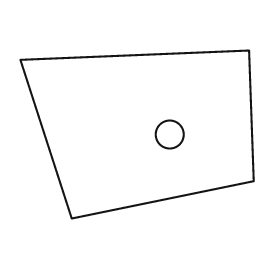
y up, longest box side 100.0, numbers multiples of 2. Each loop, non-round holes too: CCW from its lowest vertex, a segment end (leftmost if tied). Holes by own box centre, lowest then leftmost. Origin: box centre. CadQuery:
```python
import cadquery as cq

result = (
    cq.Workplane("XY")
    .moveTo(-28.0, -36.0)
    .lineTo(50.0, -20.0)
    .lineTo(48.0, 36.0)
    .lineTo(-50.0, 32.0)
    .close()
    .moveTo(14.0, 0.0)
    .circle(6.0)
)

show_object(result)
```